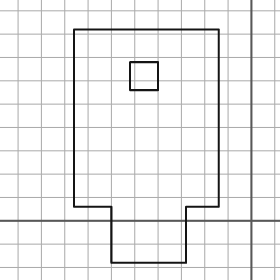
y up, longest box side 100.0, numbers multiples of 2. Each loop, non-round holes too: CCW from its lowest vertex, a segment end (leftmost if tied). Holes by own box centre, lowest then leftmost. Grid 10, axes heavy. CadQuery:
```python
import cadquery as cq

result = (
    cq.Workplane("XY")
    .moveTo(-60.0, -18.0)
    .lineTo(-28.0, -18.0)
    .lineTo(-28.0, 6.0)
    .lineTo(-14.0, 6.0)
    .lineTo(-14.0, 82.0)
    .lineTo(-76.0, 82.0)
    .lineTo(-76.0, 6.0)
    .lineTo(-60.0, 6.0)
    .close()
    .moveTo(-52.0, 56.0)
    .lineTo(-40.0, 56.0)
    .lineTo(-40.0, 68.0)
    .lineTo(-52.0, 68.0)
    .close()
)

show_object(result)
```